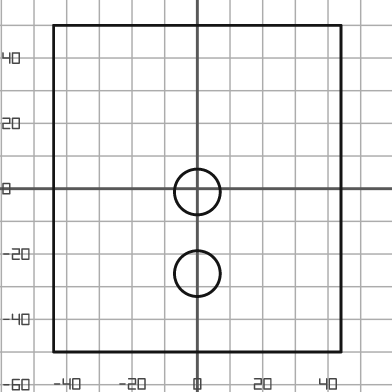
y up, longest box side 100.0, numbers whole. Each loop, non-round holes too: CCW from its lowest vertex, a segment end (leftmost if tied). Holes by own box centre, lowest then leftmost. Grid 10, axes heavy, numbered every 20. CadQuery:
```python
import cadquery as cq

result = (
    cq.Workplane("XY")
    .moveTo(-44.0, -50.0)
    .lineTo(44.0, -50.0)
    .lineTo(44.0, 50.0)
    .lineTo(-44.0, 50.0)
    .close()
    .moveTo(0.0, -26.0)
    .circle(7.0)
    .moveTo(0.0, -1.0)
    .circle(7.0)
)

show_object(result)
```